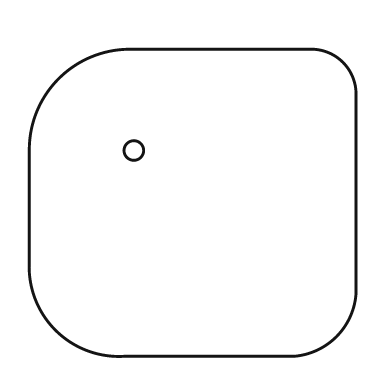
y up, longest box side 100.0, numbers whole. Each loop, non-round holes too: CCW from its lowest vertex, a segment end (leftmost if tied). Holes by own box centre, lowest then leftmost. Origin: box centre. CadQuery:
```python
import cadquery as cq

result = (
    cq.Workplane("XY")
    .moveTo(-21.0, -47.0)
    .lineTo(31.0, -47.0)
    .threePointArc((44.0, -41.0), (50.0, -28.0))
    .lineTo(50.0, 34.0)
    .threePointArc((46.0, 43.0), (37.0, 47.0))
    .lineTo(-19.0, 47.0)
    .threePointArc((-41.0, 38.0), (-50.0, 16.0))
    .lineTo(-50.0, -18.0)
    .threePointArc((-42.0, -39.0), (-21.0, -47.0))
    .close()
    .moveTo(-18.0, 16.0)
    .circle(3.0)
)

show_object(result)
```